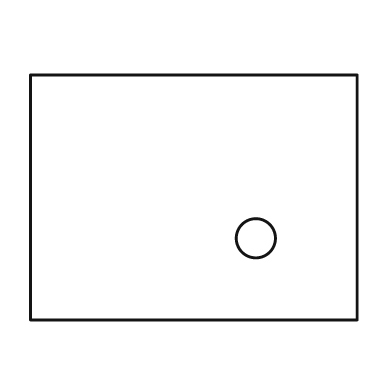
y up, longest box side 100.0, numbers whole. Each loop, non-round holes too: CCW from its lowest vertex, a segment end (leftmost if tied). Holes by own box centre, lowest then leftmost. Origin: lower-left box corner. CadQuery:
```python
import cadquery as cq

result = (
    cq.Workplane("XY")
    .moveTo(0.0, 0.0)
    .lineTo(100.0, 0.0)
    .lineTo(100.0, 75.0)
    .lineTo(0.0, 75.0)
    .close()
    .moveTo(69.0, 25.0)
    .circle(6.0)
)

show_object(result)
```